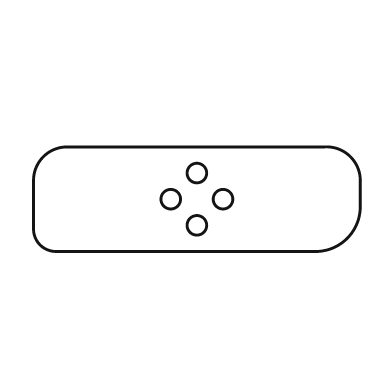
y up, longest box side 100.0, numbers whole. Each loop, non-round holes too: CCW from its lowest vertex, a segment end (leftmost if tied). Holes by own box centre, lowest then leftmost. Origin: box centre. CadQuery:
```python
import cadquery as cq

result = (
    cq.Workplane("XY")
    .moveTo(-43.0, -16.0)
    .lineTo(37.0, -16.0)
    .threePointArc((46.0, -12.0), (50.0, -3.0))
    .lineTo(50.0, 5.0)
    .threePointArc((47.0, 13.0), (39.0, 16.0))
    .lineTo(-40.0, 16.0)
    .threePointArc((-47.0, 13.0), (-50.0, 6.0))
    .lineTo(-50.0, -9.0)
    .threePointArc((-48.0, -14.0), (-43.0, -16.0))
    .close()
    .moveTo(0.0, -8.0)
    .circle(3.0)
    .moveTo(-8.0, 0.0)
    .circle(3.0)
    .moveTo(8.0, 0.0)
    .circle(3.0)
    .moveTo(0.0, 8.0)
    .circle(3.0)
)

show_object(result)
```